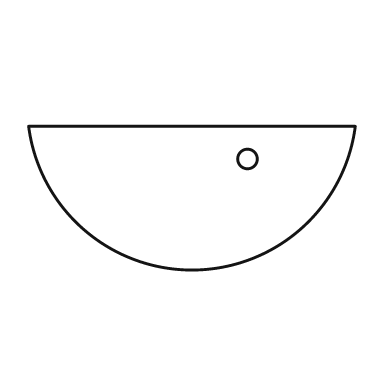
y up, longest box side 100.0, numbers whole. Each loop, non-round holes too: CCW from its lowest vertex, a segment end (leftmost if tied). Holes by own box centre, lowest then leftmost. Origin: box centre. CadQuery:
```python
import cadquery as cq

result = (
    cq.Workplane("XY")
    .moveTo(-50.0, 22.0)
    .threePointArc((0.0, -22.0), (50.0, 22.0))
    .close()
    .moveTo(17.0, 12.0)
    .circle(3.0)
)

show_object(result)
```